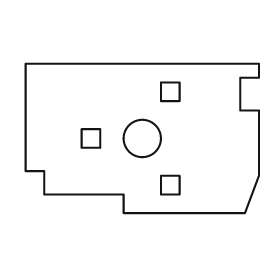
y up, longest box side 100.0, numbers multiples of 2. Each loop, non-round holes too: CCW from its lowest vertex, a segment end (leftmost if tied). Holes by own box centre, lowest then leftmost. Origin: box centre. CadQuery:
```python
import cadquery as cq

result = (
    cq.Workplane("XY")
    .moveTo(-8.0, -32.0)
    .lineTo(44.0, -32.0)
    .lineTo(50.0, -16.0)
    .lineTo(50.0, 12.0)
    .lineTo(42.0, 12.0)
    .lineTo(42.0, 26.0)
    .lineTo(50.0, 26.0)
    .lineTo(50.0, 32.0)
    .lineTo(-50.0, 32.0)
    .lineTo(-50.0, -14.0)
    .lineTo(-42.0, -14.0)
    .lineTo(-42.0, -24.0)
    .lineTo(-8.0, -24.0)
    .close()
    .moveTo(8.0, -24.0)
    .lineTo(16.0, -24.0)
    .lineTo(16.0, -16.0)
    .lineTo(8.0, -16.0)
    .close()
    .moveTo(-26.0, -4.0)
    .lineTo(-18.0, -4.0)
    .lineTo(-18.0, 4.0)
    .lineTo(-26.0, 4.0)
    .close()
    .moveTo(0.0, 0.0)
    .circle(8.0)
    .moveTo(8.0, 16.0)
    .lineTo(16.0, 16.0)
    .lineTo(16.0, 24.0)
    .lineTo(8.0, 24.0)
    .close()
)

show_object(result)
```